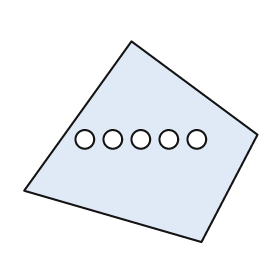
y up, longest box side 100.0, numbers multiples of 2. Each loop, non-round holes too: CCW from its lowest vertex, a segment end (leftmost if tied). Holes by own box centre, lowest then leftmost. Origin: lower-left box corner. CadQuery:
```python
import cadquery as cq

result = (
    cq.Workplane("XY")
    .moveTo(76.0, 0.0)
    .lineTo(100.0, 46.0)
    .lineTo(46.0, 86.0)
    .lineTo(0.0, 22.0)
    .close()
    .moveTo(26.0, 44.0)
    .circle(4.0)
    .moveTo(38.0, 44.0)
    .circle(4.0)
    .moveTo(50.0, 44.0)
    .circle(4.0)
    .moveTo(62.0, 44.0)
    .circle(4.0)
    .moveTo(74.0, 44.0)
    .circle(4.0)
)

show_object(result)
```